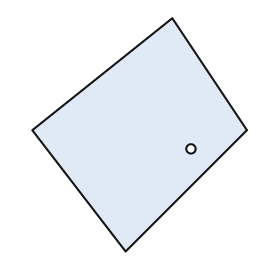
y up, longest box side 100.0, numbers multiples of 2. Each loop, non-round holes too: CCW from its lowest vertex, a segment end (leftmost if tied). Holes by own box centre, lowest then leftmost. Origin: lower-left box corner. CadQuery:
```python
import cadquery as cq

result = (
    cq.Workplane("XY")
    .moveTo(40.0, 0.0)
    .lineTo(92.0, 52.0)
    .lineTo(60.0, 100.0)
    .lineTo(0.0, 52.0)
    .close()
    .moveTo(68.0, 44.0)
    .circle(2.0)
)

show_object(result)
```